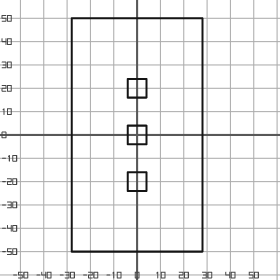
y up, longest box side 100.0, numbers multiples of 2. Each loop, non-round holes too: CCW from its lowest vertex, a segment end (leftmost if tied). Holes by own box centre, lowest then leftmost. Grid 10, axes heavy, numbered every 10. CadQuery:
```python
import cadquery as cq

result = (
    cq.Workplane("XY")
    .moveTo(-28.0, -50.0)
    .lineTo(28.0, -50.0)
    .lineTo(28.0, 50.0)
    .lineTo(-28.0, 50.0)
    .close()
    .moveTo(-4.0, -24.0)
    .lineTo(4.0, -24.0)
    .lineTo(4.0, -16.0)
    .lineTo(-4.0, -16.0)
    .close()
    .moveTo(-4.0, -4.0)
    .lineTo(4.0, -4.0)
    .lineTo(4.0, 4.0)
    .lineTo(-4.0, 4.0)
    .close()
    .moveTo(-4.0, 16.0)
    .lineTo(4.0, 16.0)
    .lineTo(4.0, 24.0)
    .lineTo(-4.0, 24.0)
    .close()
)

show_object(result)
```